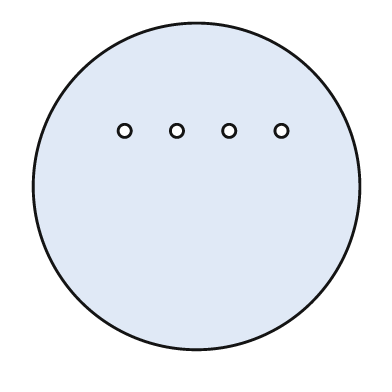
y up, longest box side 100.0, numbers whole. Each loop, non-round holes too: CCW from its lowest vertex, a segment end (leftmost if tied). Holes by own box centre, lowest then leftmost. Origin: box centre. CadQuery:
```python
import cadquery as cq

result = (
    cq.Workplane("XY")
    .moveTo(0.0, 0.0)
    .circle(50.0)
    .moveTo(-22.0, 17.0)
    .circle(2.0)
    .moveTo(-6.0, 17.0)
    .circle(2.0)
    .moveTo(10.0, 17.0)
    .circle(2.0)
    .moveTo(26.0, 17.0)
    .circle(2.0)
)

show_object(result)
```